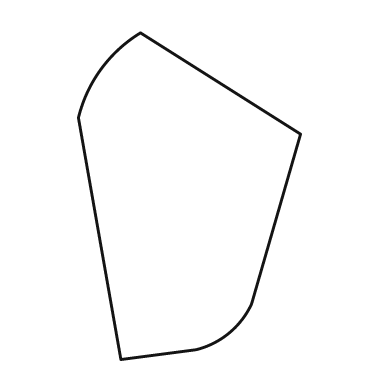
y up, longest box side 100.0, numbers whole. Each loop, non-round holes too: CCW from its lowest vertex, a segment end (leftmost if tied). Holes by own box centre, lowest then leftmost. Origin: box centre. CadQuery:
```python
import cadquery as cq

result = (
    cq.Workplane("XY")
    .moveTo(-21.0, -50.0)
    .lineTo(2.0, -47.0)
    .threePointArc((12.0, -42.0), (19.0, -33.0))
    .lineTo(34.0, 19.0)
    .lineTo(-15.0, 50.0)
    .threePointArc((-27.0, 39.0), (-34.0, 24.0))
    .close()
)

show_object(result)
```